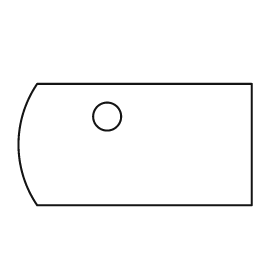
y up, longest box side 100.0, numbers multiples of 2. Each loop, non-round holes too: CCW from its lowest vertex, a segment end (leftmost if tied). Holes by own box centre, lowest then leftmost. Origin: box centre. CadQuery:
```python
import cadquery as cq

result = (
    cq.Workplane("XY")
    .moveTo(-42.0, -26.0)
    .lineTo(50.0, -26.0)
    .lineTo(50.0, 26.0)
    .lineTo(-42.0, 26.0)
    .threePointArc((-50.0, 0.0), (-42.0, -26.0))
    .close()
    .moveTo(-12.0, 12.0)
    .circle(6.0)
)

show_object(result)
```